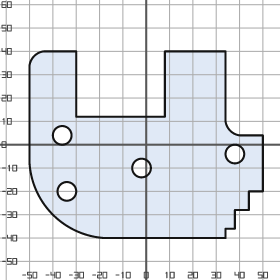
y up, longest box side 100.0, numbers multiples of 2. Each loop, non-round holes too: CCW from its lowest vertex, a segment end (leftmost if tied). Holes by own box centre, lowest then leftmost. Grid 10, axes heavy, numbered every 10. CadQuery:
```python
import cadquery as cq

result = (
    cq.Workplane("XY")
    .moveTo(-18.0, -40.0)
    .lineTo(34.0, -40.0)
    .lineTo(34.0, -36.0)
    .lineTo(38.0, -36.0)
    .lineTo(38.0, -28.0)
    .lineTo(44.0, -28.0)
    .lineTo(44.0, -20.0)
    .lineTo(50.0, -20.0)
    .lineTo(50.0, 4.0)
    .lineTo(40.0, 4.0)
    .threePointArc((36.0, 6.0), (34.0, 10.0))
    .lineTo(34.0, 40.0)
    .lineTo(8.0, 40.0)
    .lineTo(8.0, 12.0)
    .lineTo(-30.0, 12.0)
    .lineTo(-30.0, 40.0)
    .lineTo(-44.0, 40.0)
    .threePointArc((-48.0, 38.0), (-50.0, 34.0))
    .lineTo(-50.0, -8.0)
    .threePointArc((-40.0, -30.0), (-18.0, -40.0))
    .close()
    .moveTo(-34.0, -20.0)
    .circle(4.0)
    .moveTo(-2.0, -10.0)
    .circle(4.0)
    .moveTo(38.0, -4.0)
    .circle(4.0)
    .moveTo(-36.0, 4.0)
    .circle(4.0)
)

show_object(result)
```